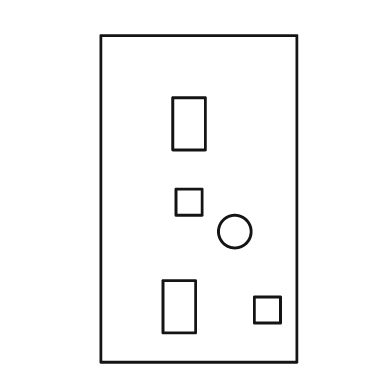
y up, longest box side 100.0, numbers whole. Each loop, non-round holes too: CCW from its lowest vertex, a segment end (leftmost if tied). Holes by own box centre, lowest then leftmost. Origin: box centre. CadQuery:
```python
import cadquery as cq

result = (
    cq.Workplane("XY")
    .moveTo(-30.0, -50.0)
    .lineTo(30.0, -50.0)
    .lineTo(30.0, 50.0)
    .lineTo(-30.0, 50.0)
    .close()
    .moveTo(17.0, -38.0)
    .lineTo(25.0, -38.0)
    .lineTo(25.0, -30.0)
    .lineTo(17.0, -30.0)
    .close()
    .moveTo(-11.0, -41.0)
    .lineTo(-1.0, -41.0)
    .lineTo(-1.0, -25.0)
    .lineTo(-11.0, -25.0)
    .close()
    .moveTo(11.0, -10.0)
    .circle(5.0)
    .moveTo(-7.0, -5.0)
    .lineTo(1.0, -5.0)
    .lineTo(1.0, 3.0)
    .lineTo(-7.0, 3.0)
    .close()
    .moveTo(-8.0, 15.0)
    .lineTo(2.0, 15.0)
    .lineTo(2.0, 31.0)
    .lineTo(-8.0, 31.0)
    .close()
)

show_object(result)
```